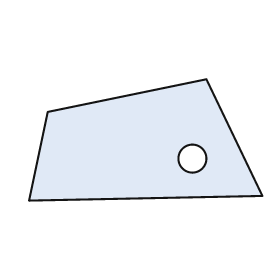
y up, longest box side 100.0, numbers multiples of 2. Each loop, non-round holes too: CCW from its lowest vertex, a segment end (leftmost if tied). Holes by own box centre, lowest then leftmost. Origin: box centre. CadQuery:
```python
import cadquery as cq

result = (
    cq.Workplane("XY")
    .moveTo(-50.0, -26.0)
    .lineTo(50.0, -24.0)
    .lineTo(26.0, 26.0)
    .lineTo(-42.0, 12.0)
    .close()
    .moveTo(20.0, -8.0)
    .circle(6.0)
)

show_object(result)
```